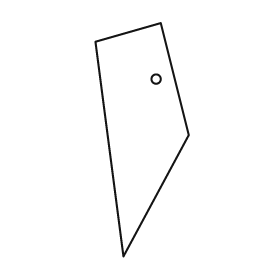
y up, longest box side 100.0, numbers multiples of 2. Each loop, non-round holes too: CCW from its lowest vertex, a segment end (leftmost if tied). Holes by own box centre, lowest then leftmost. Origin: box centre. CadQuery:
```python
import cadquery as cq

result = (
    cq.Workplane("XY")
    .moveTo(-8.0, -50.0)
    .lineTo(20.0, 2.0)
    .lineTo(8.0, 50.0)
    .lineTo(-20.0, 42.0)
    .close()
    .moveTo(6.0, 26.0)
    .circle(2.0)
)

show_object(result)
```